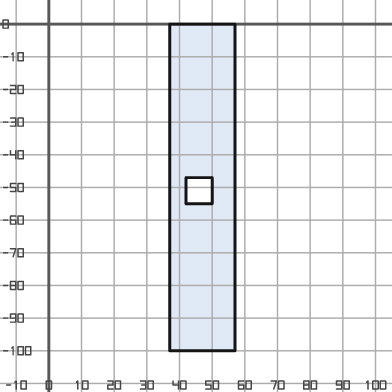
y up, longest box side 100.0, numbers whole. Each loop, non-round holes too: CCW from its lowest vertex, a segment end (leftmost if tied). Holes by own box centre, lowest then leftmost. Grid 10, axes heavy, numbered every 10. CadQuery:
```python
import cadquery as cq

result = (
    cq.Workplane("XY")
    .moveTo(37.0, -100.0)
    .lineTo(57.0, -100.0)
    .lineTo(57.0, 0.0)
    .lineTo(37.0, 0.0)
    .close()
    .moveTo(42.0, -55.0)
    .lineTo(50.0, -55.0)
    .lineTo(50.0, -47.0)
    .lineTo(42.0, -47.0)
    .close()
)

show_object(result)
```